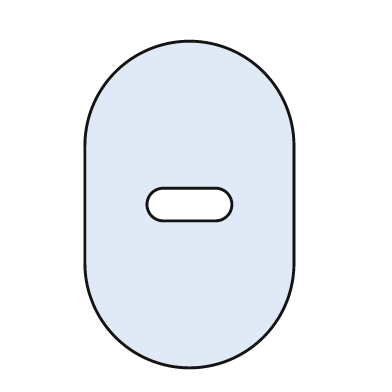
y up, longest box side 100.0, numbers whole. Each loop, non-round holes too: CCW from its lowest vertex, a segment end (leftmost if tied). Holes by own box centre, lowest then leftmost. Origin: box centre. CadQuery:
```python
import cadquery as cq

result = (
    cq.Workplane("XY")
    .moveTo(-32.0, -18.0)
    .threePointArc((0.0, -50.0), (32.0, -18.0))
    .lineTo(32.0, 18.0)
    .threePointArc((0.0, 50.0), (-32.0, 18.0))
    .close()
    .moveTo(-8.0, -5.0)
    .lineTo(8.0, -5.0)
    .threePointArc((13.0, 0.0), (8.0, 5.0))
    .lineTo(-8.0, 5.0)
    .threePointArc((-13.0, 0.0), (-8.0, -5.0))
    .close()
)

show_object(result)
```